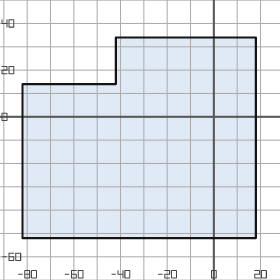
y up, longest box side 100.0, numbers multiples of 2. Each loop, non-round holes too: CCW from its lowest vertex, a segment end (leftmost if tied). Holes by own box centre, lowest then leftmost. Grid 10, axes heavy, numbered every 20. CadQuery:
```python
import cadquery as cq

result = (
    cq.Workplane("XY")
    .moveTo(-82.0, -52.0)
    .lineTo(18.0, -52.0)
    .lineTo(18.0, 34.0)
    .lineTo(-42.0, 34.0)
    .lineTo(-42.0, 14.0)
    .lineTo(-82.0, 14.0)
    .close()
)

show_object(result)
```